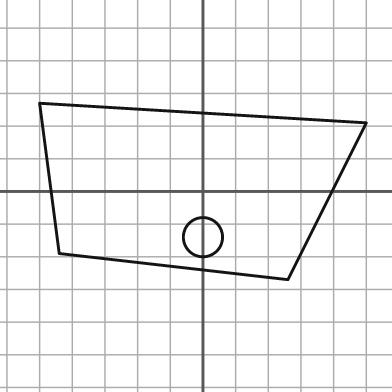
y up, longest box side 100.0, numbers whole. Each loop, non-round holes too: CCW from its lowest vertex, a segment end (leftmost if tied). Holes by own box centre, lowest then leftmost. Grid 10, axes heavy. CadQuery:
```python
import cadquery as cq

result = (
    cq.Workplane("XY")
    .moveTo(26.0, -27.0)
    .lineTo(50.0, 21.0)
    .lineTo(-50.0, 27.0)
    .lineTo(-44.0, -19.0)
    .close()
    .moveTo(0.0, -14.0)
    .circle(6.0)
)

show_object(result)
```